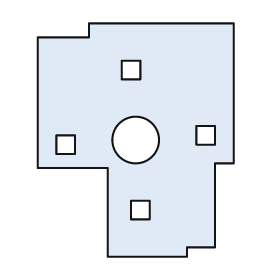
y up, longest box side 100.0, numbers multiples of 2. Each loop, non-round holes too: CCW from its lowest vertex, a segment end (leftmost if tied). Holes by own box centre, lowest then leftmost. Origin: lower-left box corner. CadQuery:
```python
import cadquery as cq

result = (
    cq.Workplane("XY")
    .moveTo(30.0, 0.0)
    .lineTo(64.0, 0.0)
    .lineTo(64.0, 4.0)
    .lineTo(76.0, 4.0)
    .lineTo(76.0, 40.0)
    .lineTo(84.0, 40.0)
    .lineTo(84.0, 100.0)
    .lineTo(22.0, 100.0)
    .lineTo(22.0, 94.0)
    .lineTo(0.0, 94.0)
    .lineTo(0.0, 38.0)
    .lineTo(30.0, 38.0)
    .close()
    .moveTo(40.0, 16.0)
    .lineTo(48.0, 16.0)
    .lineTo(48.0, 24.0)
    .lineTo(40.0, 24.0)
    .close()
    .moveTo(8.0, 44.0)
    .lineTo(16.0, 44.0)
    .lineTo(16.0, 52.0)
    .lineTo(8.0, 52.0)
    .close()
    .moveTo(42.0, 50.0)
    .circle(10.0)
    .moveTo(68.0, 48.0)
    .lineTo(76.0, 48.0)
    .lineTo(76.0, 56.0)
    .lineTo(68.0, 56.0)
    .close()
    .moveTo(36.0, 76.0)
    .lineTo(44.0, 76.0)
    .lineTo(44.0, 84.0)
    .lineTo(36.0, 84.0)
    .close()
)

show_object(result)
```